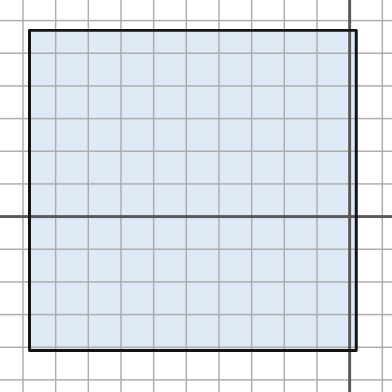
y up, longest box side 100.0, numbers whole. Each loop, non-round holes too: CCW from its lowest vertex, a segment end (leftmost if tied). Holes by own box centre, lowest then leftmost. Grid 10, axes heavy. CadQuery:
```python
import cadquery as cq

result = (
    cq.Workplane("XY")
    .moveTo(-98.0, -41.0)
    .lineTo(2.0, -41.0)
    .lineTo(2.0, 57.0)
    .lineTo(-98.0, 57.0)
    .close()
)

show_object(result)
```